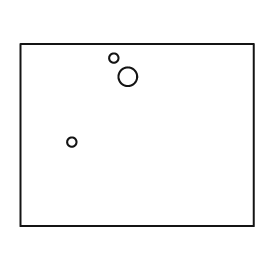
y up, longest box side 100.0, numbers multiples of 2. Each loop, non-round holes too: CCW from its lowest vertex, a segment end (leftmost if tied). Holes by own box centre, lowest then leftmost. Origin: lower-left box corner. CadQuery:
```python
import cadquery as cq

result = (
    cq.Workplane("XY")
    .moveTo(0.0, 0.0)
    .lineTo(100.0, 0.0)
    .lineTo(100.0, 78.0)
    .lineTo(0.0, 78.0)
    .close()
    .moveTo(22.0, 36.0)
    .circle(2.0)
    .moveTo(46.0, 64.0)
    .circle(4.0)
    .moveTo(40.0, 72.0)
    .circle(2.0)
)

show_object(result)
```